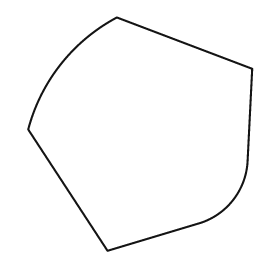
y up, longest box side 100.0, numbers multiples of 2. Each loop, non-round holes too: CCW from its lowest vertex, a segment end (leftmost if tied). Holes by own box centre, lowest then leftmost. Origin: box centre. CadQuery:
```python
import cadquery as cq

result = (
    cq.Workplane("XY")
    .moveTo(-14.0, -50.0)
    .lineTo(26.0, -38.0)
    .threePointArc((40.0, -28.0), (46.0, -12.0))
    .lineTo(48.0, 28.0)
    .lineTo(-10.0, 50.0)
    .threePointArc((-34.0, 30.0), (-48.0, 2.0))
    .close()
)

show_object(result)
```